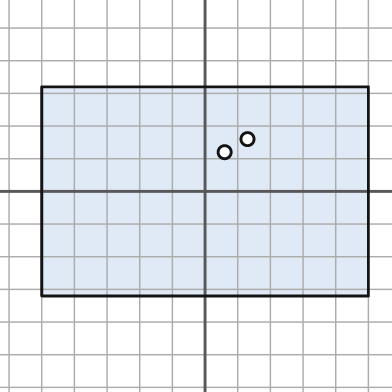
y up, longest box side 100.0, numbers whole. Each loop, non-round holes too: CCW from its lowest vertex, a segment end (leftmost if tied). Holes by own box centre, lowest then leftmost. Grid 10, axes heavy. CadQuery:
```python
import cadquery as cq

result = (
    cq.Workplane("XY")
    .moveTo(-50.0, -32.0)
    .lineTo(50.0, -32.0)
    .lineTo(50.0, 32.0)
    .lineTo(-50.0, 32.0)
    .close()
    .moveTo(6.0, 12.0)
    .circle(2.0)
    .moveTo(13.0, 16.0)
    .circle(2.0)
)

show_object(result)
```